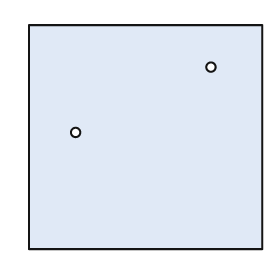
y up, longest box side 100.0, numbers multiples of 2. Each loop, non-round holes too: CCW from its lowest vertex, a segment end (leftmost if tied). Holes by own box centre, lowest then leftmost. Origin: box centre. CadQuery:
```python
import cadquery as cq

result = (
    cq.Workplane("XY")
    .moveTo(-50.0, -48.0)
    .lineTo(50.0, -48.0)
    .lineTo(50.0, 48.0)
    .lineTo(-50.0, 48.0)
    .close()
    .moveTo(-30.0, 2.0)
    .circle(2.0)
    .moveTo(28.0, 30.0)
    .circle(2.0)
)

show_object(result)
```